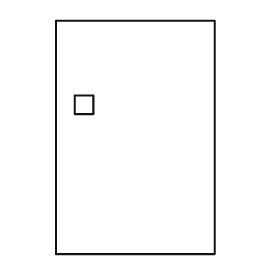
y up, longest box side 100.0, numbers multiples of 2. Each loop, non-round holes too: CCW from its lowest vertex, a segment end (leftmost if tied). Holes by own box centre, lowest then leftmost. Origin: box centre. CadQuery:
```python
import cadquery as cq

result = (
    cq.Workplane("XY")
    .moveTo(-34.0, -50.0)
    .lineTo(34.0, -50.0)
    .lineTo(34.0, 50.0)
    .lineTo(-34.0, 50.0)
    .close()
    .moveTo(-26.0, 10.0)
    .lineTo(-18.0, 10.0)
    .lineTo(-18.0, 18.0)
    .lineTo(-26.0, 18.0)
    .close()
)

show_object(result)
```